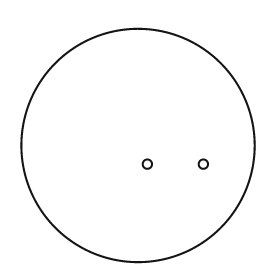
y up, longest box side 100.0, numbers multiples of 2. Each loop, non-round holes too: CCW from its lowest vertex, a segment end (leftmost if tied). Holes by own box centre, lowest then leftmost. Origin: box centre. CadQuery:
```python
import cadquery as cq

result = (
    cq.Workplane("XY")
    .moveTo(0.0, 0.0)
    .circle(50.0)
    .moveTo(4.0, -8.0)
    .circle(2.0)
    .moveTo(28.0, -8.0)
    .circle(2.0)
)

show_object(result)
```